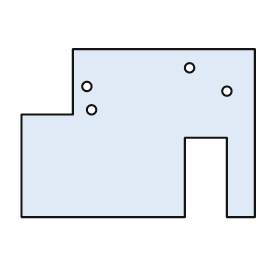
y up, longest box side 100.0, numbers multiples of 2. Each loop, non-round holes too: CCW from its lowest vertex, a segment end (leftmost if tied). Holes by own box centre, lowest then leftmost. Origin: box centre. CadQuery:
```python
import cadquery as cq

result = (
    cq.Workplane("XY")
    .moveTo(-50.0, -36.0)
    .lineTo(20.0, -36.0)
    .lineTo(20.0, -2.0)
    .lineTo(38.0, -2.0)
    .lineTo(38.0, -36.0)
    .lineTo(50.0, -36.0)
    .lineTo(50.0, 36.0)
    .lineTo(-28.0, 36.0)
    .lineTo(-28.0, 8.0)
    .lineTo(-50.0, 8.0)
    .close()
    .moveTo(-20.0, 10.0)
    .circle(2.0)
    .moveTo(38.0, 18.0)
    .circle(2.0)
    .moveTo(-22.0, 20.0)
    .circle(2.0)
    .moveTo(22.0, 28.0)
    .circle(2.0)
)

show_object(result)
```